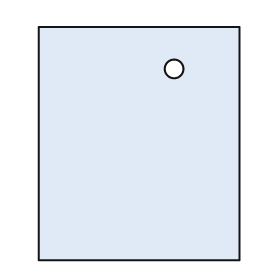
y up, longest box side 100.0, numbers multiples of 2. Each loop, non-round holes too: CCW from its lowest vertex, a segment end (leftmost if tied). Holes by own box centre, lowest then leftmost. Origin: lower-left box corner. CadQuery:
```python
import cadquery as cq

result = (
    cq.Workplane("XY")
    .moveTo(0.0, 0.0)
    .lineTo(86.0, 0.0)
    .lineTo(86.0, 100.0)
    .lineTo(0.0, 100.0)
    .close()
    .moveTo(58.0, 82.0)
    .circle(4.0)
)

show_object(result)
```